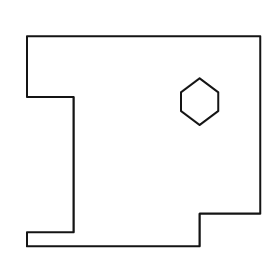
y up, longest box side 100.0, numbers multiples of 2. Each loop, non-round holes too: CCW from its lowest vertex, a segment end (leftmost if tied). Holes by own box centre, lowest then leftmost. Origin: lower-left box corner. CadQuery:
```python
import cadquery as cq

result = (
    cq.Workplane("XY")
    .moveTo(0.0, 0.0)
    .lineTo(74.0, 0.0)
    .lineTo(74.0, 14.0)
    .lineTo(100.0, 14.0)
    .lineTo(100.0, 90.0)
    .lineTo(0.0, 90.0)
    .lineTo(0.0, 64.0)
    .lineTo(20.0, 64.0)
    .lineTo(20.0, 6.0)
    .lineTo(0.0, 6.0)
    .close()
    .moveTo(74.0, 52.0)
    .lineTo(82.0, 58.0)
    .lineTo(82.0, 66.0)
    .lineTo(74.0, 72.0)
    .lineTo(66.0, 66.0)
    .lineTo(66.0, 58.0)
    .close()
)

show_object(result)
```